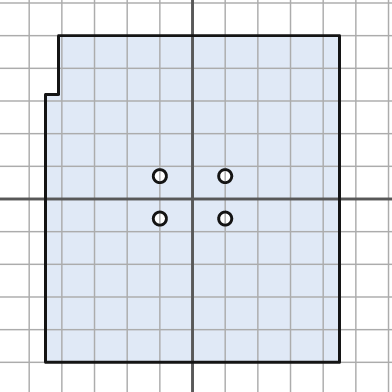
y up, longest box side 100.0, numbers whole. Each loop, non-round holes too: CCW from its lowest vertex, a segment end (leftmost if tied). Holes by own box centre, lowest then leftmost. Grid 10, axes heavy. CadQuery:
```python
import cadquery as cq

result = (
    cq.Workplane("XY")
    .moveTo(-45.0, -50.0)
    .lineTo(45.0, -50.0)
    .lineTo(45.0, 50.0)
    .lineTo(-41.0, 50.0)
    .lineTo(-41.0, 32.0)
    .lineTo(-45.0, 32.0)
    .close()
    .moveTo(-10.0, -6.0)
    .circle(2.0)
    .moveTo(10.0, -6.0)
    .circle(2.0)
    .moveTo(-10.0, 7.0)
    .circle(2.0)
    .moveTo(10.0, 7.0)
    .circle(2.0)
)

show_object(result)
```